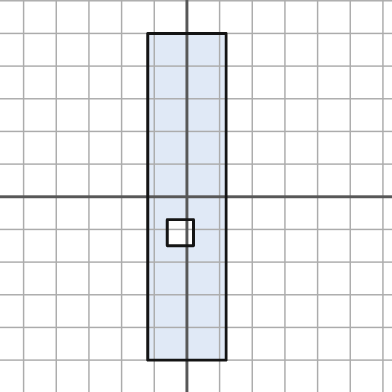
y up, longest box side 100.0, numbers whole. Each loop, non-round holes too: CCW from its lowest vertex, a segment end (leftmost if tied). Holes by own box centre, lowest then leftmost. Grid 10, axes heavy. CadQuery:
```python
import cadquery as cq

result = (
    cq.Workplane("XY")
    .moveTo(-12.0, -50.0)
    .lineTo(12.0, -50.0)
    .lineTo(12.0, 50.0)
    .lineTo(-12.0, 50.0)
    .close()
    .moveTo(-6.0, -15.0)
    .lineTo(2.0, -15.0)
    .lineTo(2.0, -7.0)
    .lineTo(-6.0, -7.0)
    .close()
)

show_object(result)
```